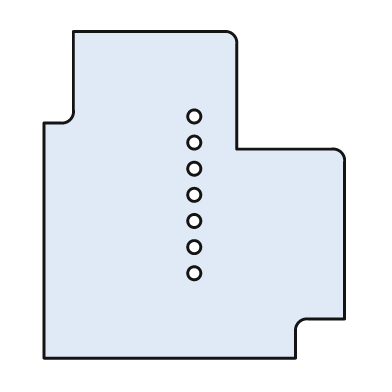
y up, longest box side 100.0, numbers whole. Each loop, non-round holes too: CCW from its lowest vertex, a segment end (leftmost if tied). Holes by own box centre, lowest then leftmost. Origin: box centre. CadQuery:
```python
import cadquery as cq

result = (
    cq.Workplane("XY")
    .moveTo(-46.0, -50.0)
    .lineTo(31.0, -50.0)
    .lineTo(31.0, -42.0)
    .threePointArc((32.0, -39.0), (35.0, -38.0))
    .lineTo(46.0, -38.0)
    .lineTo(46.0, 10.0)
    .threePointArc((45.0, 13.0), (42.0, 14.0))
    .lineTo(13.0, 14.0)
    .lineTo(13.0, 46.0)
    .threePointArc((12.0, 49.0), (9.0, 50.0))
    .lineTo(-37.0, 50.0)
    .lineTo(-37.0, 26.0)
    .threePointArc((-38.0, 23.0), (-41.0, 22.0))
    .lineTo(-46.0, 22.0)
    .close()
    .moveTo(0.0, -24.0)
    .circle(2.0)
    .moveTo(0.0, -16.0)
    .circle(2.0)
    .moveTo(0.0, -8.0)
    .circle(2.0)
    .moveTo(0.0, 0.0)
    .circle(2.0)
    .moveTo(0.0, 8.0)
    .circle(2.0)
    .moveTo(0.0, 16.0)
    .circle(2.0)
    .moveTo(0.0, 24.0)
    .circle(2.0)
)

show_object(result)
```